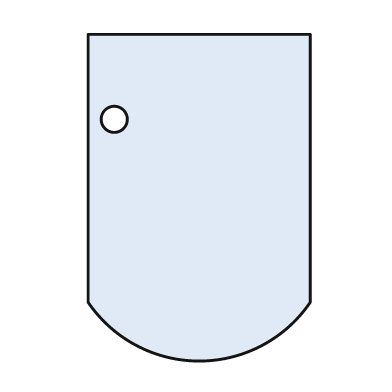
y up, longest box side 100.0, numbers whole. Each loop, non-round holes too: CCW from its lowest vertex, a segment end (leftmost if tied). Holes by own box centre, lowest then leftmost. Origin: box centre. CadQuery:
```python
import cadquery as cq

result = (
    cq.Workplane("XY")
    .moveTo(-34.0, -32.0)
    .threePointArc((0.0, -50.0), (34.0, -32.0))
    .lineTo(34.0, 50.0)
    .lineTo(-34.0, 50.0)
    .close()
    .moveTo(-26.0, 24.0)
    .circle(4.0)
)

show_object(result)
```